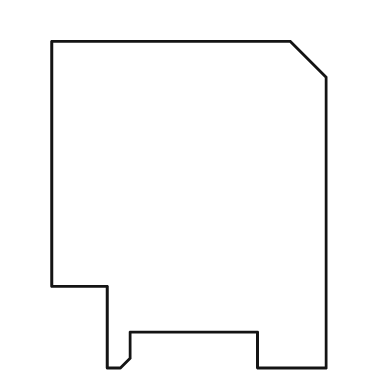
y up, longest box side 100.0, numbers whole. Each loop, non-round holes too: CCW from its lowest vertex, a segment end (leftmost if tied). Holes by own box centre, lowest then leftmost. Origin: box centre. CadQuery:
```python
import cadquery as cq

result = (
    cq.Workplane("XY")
    .moveTo(-25.0, -50.0)
    .lineTo(-21.0, -50.0)
    .lineTo(-18.0, -47.0)
    .lineTo(-18.0, -39.0)
    .lineTo(21.0, -39.0)
    .lineTo(21.0, -50.0)
    .lineTo(42.0, -50.0)
    .lineTo(42.0, 39.0)
    .lineTo(31.0, 50.0)
    .lineTo(-42.0, 50.0)
    .lineTo(-42.0, -25.0)
    .lineTo(-25.0, -25.0)
    .close()
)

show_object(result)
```